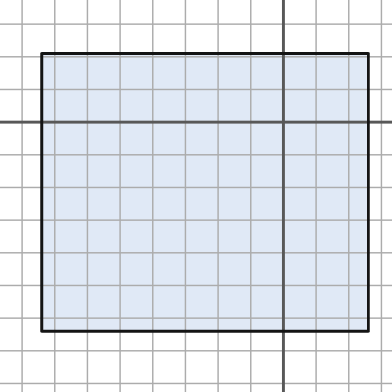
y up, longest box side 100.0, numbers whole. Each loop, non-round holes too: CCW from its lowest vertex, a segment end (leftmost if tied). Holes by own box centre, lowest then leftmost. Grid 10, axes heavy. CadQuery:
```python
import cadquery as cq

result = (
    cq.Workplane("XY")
    .moveTo(-74.0, -64.0)
    .lineTo(26.0, -64.0)
    .lineTo(26.0, 21.0)
    .lineTo(-74.0, 21.0)
    .close()
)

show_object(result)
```